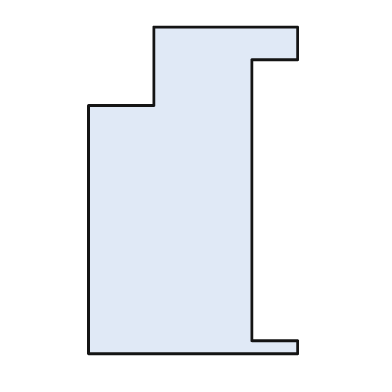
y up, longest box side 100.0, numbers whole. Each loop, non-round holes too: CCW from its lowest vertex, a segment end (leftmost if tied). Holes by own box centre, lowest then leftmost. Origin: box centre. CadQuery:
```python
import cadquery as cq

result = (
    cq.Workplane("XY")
    .moveTo(-32.0, -50.0)
    .lineTo(32.0, -50.0)
    .lineTo(32.0, -46.0)
    .lineTo(18.0, -46.0)
    .lineTo(18.0, 40.0)
    .lineTo(32.0, 40.0)
    .lineTo(32.0, 50.0)
    .lineTo(-12.0, 50.0)
    .lineTo(-12.0, 26.0)
    .lineTo(-32.0, 26.0)
    .close()
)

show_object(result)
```